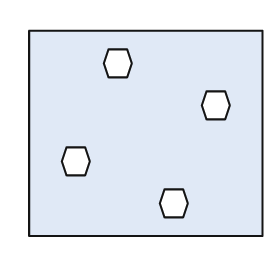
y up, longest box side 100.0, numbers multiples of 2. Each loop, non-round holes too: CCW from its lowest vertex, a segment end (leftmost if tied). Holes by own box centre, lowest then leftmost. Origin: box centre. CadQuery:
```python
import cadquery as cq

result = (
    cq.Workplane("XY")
    .moveTo(-50.0, -44.0)
    .lineTo(50.0, -44.0)
    .lineTo(50.0, 44.0)
    .lineTo(-50.0, 44.0)
    .close()
    .moveTo(8.0, -36.0)
    .lineTo(16.0, -36.0)
    .lineTo(18.0, -30.0)
    .lineTo(16.0, -24.0)
    .lineTo(8.0, -24.0)
    .lineTo(6.0, -30.0)
    .close()
    .moveTo(-34.0, -18.0)
    .lineTo(-26.0, -18.0)
    .lineTo(-24.0, -12.0)
    .lineTo(-26.0, -6.0)
    .lineTo(-34.0, -6.0)
    .lineTo(-36.0, -12.0)
    .close()
    .moveTo(26.0, 6.0)
    .lineTo(34.0, 6.0)
    .lineTo(36.0, 12.0)
    .lineTo(34.0, 18.0)
    .lineTo(26.0, 18.0)
    .lineTo(24.0, 12.0)
    .close()
    .moveTo(-16.0, 24.0)
    .lineTo(-8.0, 24.0)
    .lineTo(-6.0, 30.0)
    .lineTo(-8.0, 36.0)
    .lineTo(-16.0, 36.0)
    .lineTo(-18.0, 30.0)
    .close()
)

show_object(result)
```